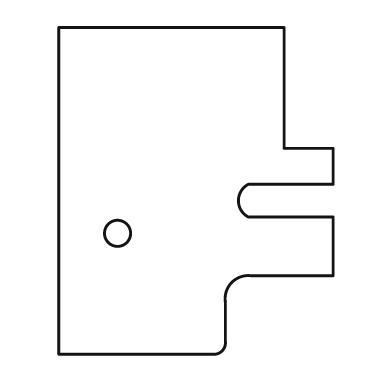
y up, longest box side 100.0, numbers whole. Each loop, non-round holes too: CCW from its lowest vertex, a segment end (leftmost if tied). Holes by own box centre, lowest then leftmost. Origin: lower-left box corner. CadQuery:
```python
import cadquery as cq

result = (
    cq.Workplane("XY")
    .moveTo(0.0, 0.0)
    .lineTo(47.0, 0.0)
    .threePointArc((50.0, 1.0), (51.0, 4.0))
    .lineTo(51.0, 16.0)
    .threePointArc((53.0, 22.0), (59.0, 24.0))
    .lineTo(84.0, 24.0)
    .lineTo(84.0, 42.0)
    .lineTo(58.0, 42.0)
    .threePointArc((55.0, 47.0), (58.0, 52.0))
    .lineTo(84.0, 52.0)
    .lineTo(84.0, 63.0)
    .lineTo(69.0, 63.0)
    .lineTo(69.0, 100.0)
    .lineTo(0.0, 100.0)
    .close()
    .moveTo(18.0, 37.0)
    .circle(4.0)
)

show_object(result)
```